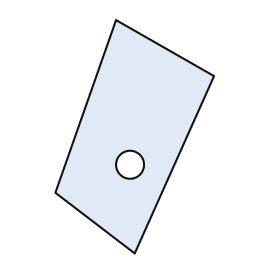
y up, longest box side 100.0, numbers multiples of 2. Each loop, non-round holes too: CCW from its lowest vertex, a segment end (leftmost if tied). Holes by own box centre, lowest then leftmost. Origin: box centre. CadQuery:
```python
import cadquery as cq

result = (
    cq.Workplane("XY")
    .moveTo(0.0, -50.0)
    .lineTo(34.0, 26.0)
    .lineTo(-8.0, 50.0)
    .lineTo(-34.0, -24.0)
    .close()
    .moveTo(-2.0, -12.0)
    .circle(6.0)
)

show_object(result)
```